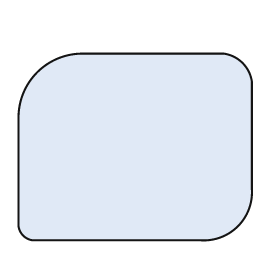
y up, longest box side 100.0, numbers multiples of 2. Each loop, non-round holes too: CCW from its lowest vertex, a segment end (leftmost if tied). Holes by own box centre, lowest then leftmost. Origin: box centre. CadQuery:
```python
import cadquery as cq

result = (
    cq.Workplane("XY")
    .moveTo(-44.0, -40.0)
    .lineTo(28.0, -40.0)
    .threePointArc((44.0, -34.0), (50.0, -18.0))
    .lineTo(50.0, 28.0)
    .threePointArc((46.0, 36.0), (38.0, 40.0))
    .lineTo(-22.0, 40.0)
    .threePointArc((-42.0, 32.0), (-50.0, 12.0))
    .lineTo(-50.0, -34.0)
    .threePointArc((-48.0, -38.0), (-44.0, -40.0))
    .close()
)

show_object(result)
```